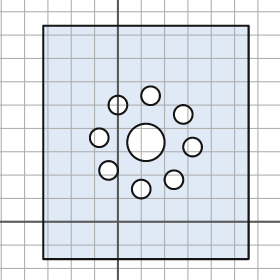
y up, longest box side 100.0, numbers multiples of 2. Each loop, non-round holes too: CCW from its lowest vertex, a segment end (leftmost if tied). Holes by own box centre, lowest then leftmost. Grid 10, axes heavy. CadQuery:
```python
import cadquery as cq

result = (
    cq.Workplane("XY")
    .moveTo(-32.0, -16.0)
    .lineTo(56.0, -16.0)
    .lineTo(56.0, 84.0)
    .lineTo(-32.0, 84.0)
    .close()
    .moveTo(10.0, 14.0)
    .circle(4.0)
    .moveTo(24.0, 18.0)
    .circle(4.0)
    .moveTo(-4.0, 22.0)
    .circle(4.0)
    .moveTo(32.0, 32.0)
    .circle(4.0)
    .moveTo(12.0, 34.0)
    .circle(8.0)
    .moveTo(-8.0, 36.0)
    .circle(4.0)
    .moveTo(28.0, 46.0)
    .circle(4.0)
    .moveTo(0.0, 50.0)
    .circle(4.0)
    .moveTo(14.0, 54.0)
    .circle(4.0)
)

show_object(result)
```